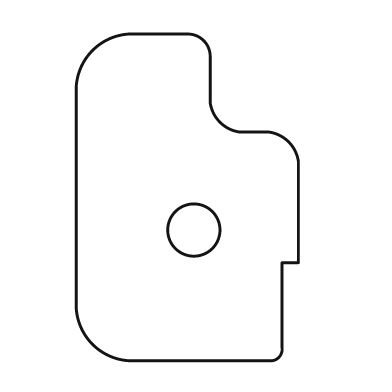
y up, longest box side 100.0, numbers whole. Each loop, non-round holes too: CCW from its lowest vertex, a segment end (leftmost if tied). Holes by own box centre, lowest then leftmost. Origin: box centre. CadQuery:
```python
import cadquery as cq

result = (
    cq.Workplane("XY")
    .moveTo(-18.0, -50.0)
    .lineTo(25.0, -50.0)
    .threePointArc((28.0, -49.0), (29.0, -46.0))
    .lineTo(29.0, -20.0)
    .lineTo(34.0, -20.0)
    .lineTo(34.0, 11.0)
    .threePointArc((31.0, 17.0), (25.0, 20.0))
    .lineTo(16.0, 20.0)
    .threePointArc((10.0, 23.0), (7.0, 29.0))
    .lineTo(7.0, 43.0)
    .threePointArc((5.0, 48.0), (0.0, 50.0))
    .lineTo(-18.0, 50.0)
    .threePointArc((-29.0, 45.0), (-34.0, 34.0))
    .lineTo(-34.0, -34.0)
    .threePointArc((-29.0, -45.0), (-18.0, -50.0))
    .close()
    .moveTo(2.0, -10.0)
    .circle(8.0)
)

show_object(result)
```